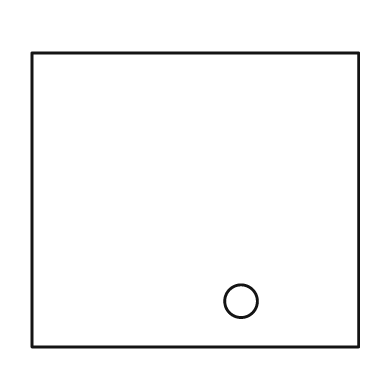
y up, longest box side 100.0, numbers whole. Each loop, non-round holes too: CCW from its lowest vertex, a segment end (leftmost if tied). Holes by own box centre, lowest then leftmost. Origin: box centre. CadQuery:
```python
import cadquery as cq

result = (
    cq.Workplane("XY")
    .moveTo(-50.0, -45.0)
    .lineTo(50.0, -45.0)
    .lineTo(50.0, 45.0)
    .lineTo(-50.0, 45.0)
    .close()
    .moveTo(14.0, -31.0)
    .circle(5.0)
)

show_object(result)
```